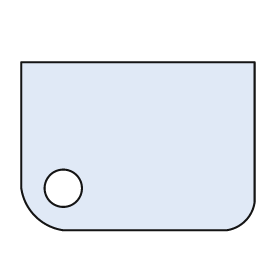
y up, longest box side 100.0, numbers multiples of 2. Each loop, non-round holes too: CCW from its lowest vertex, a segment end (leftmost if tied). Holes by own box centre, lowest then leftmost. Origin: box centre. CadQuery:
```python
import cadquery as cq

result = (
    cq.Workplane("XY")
    .moveTo(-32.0, -36.0)
    .lineTo(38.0, -36.0)
    .threePointArc((46.0, -32.0), (50.0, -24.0))
    .lineTo(50.0, 36.0)
    .lineTo(-50.0, 36.0)
    .lineTo(-50.0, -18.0)
    .threePointArc((-44.0, -30.0), (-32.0, -36.0))
    .close()
    .moveTo(-32.0, -18.0)
    .circle(8.0)
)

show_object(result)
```